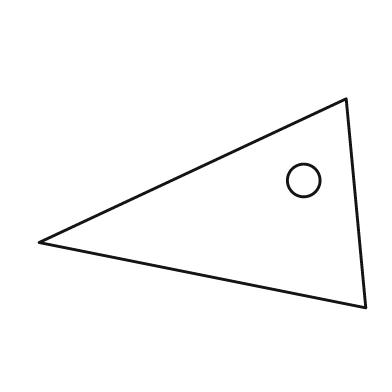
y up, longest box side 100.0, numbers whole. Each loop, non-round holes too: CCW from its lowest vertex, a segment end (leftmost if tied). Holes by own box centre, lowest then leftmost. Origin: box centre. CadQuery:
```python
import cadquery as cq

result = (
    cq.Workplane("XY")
    .moveTo(50.0, -32.0)
    .lineTo(44.0, 32.0)
    .lineTo(-50.0, -12.0)
    .close()
    .moveTo(31.0, 7.0)
    .circle(5.0)
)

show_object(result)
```